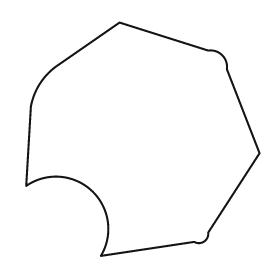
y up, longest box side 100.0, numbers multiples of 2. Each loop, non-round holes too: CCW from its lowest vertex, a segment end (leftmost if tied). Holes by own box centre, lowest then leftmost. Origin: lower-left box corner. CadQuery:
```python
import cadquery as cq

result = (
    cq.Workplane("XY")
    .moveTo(32.0, 0.0)
    .lineTo(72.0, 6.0)
    .threePointArc((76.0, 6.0), (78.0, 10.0))
    .lineTo(100.0, 44.0)
    .lineTo(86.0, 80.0)
    .threePointArc((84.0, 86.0), (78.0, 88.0))
    .lineTo(40.0, 100.0)
    .lineTo(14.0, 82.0)
    .threePointArc((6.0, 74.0), (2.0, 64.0))
    .lineTo(0.0, 30.0)
    .threePointArc((28.0, 28.0), (32.0, 0.0))
    .close()
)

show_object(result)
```